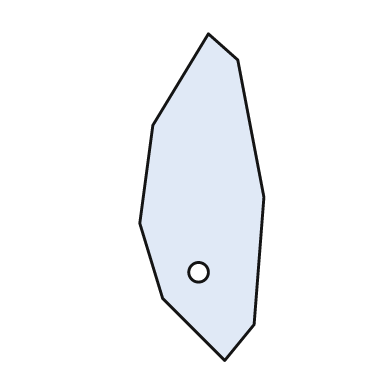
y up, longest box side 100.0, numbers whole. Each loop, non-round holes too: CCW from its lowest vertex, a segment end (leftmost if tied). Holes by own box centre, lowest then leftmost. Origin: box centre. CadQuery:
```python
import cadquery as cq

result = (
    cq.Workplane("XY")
    .moveTo(7.0, -50.0)
    .lineTo(16.0, -39.0)
    .lineTo(19.0, 0.0)
    .lineTo(11.0, 42.0)
    .lineTo(2.0, 50.0)
    .lineTo(-15.0, 22.0)
    .lineTo(-19.0, -8.0)
    .lineTo(-12.0, -31.0)
    .close()
    .moveTo(-1.0, -23.0)
    .circle(3.0)
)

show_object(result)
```